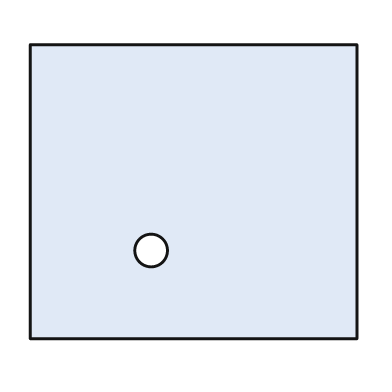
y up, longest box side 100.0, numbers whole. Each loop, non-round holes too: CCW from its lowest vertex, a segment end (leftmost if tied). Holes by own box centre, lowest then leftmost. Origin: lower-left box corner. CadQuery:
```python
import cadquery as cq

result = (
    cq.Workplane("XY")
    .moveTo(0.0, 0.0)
    .lineTo(100.0, 0.0)
    .lineTo(100.0, 90.0)
    .lineTo(0.0, 90.0)
    .close()
    .moveTo(37.0, 27.0)
    .circle(5.0)
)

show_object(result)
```